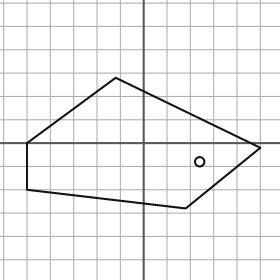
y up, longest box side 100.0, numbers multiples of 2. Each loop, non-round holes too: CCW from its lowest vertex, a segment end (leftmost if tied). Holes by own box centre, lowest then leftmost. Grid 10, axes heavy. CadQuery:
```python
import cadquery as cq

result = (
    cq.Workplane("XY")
    .moveTo(18.0, -28.0)
    .lineTo(50.0, -2.0)
    .lineTo(-12.0, 28.0)
    .lineTo(-50.0, 0.0)
    .lineTo(-50.0, -20.0)
    .close()
    .moveTo(24.0, -8.0)
    .circle(2.0)
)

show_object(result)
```